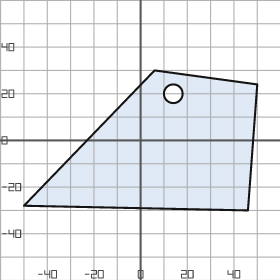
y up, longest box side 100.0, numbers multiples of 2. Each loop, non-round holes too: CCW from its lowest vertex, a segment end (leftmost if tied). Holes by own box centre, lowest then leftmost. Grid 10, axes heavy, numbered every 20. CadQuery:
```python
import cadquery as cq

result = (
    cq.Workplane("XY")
    .moveTo(46.0, -30.0)
    .lineTo(50.0, 24.0)
    .lineTo(6.0, 30.0)
    .lineTo(-50.0, -28.0)
    .close()
    .moveTo(14.0, 20.0)
    .circle(4.0)
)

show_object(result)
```